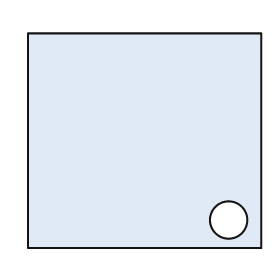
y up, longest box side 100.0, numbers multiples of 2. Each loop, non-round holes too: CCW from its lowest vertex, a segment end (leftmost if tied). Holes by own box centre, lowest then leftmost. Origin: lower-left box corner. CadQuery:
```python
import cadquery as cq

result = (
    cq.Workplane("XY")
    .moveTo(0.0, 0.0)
    .lineTo(100.0, 0.0)
    .lineTo(100.0, 92.0)
    .lineTo(0.0, 92.0)
    .close()
    .moveTo(86.0, 12.0)
    .circle(8.0)
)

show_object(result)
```